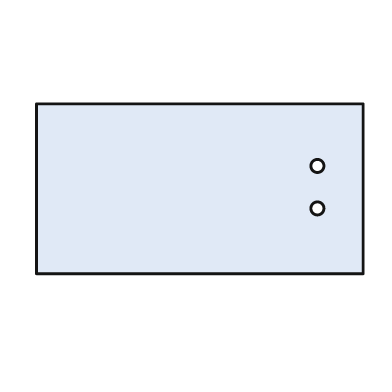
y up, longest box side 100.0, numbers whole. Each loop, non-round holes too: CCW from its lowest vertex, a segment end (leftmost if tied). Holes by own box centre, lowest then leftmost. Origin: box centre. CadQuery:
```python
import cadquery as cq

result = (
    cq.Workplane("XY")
    .moveTo(-50.0, -26.0)
    .lineTo(50.0, -26.0)
    .lineTo(50.0, 26.0)
    .lineTo(-50.0, 26.0)
    .close()
    .moveTo(36.0, -6.0)
    .circle(2.0)
    .moveTo(36.0, 7.0)
    .circle(2.0)
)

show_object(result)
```